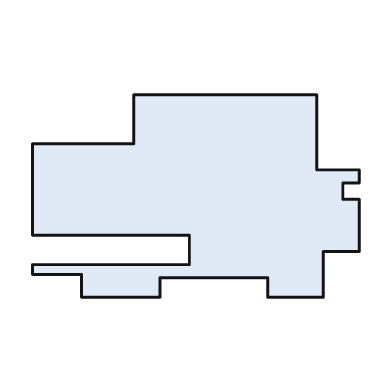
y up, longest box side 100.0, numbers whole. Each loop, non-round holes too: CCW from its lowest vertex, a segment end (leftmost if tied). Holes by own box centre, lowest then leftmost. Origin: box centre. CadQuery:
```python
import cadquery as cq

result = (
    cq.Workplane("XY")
    .moveTo(-35.0, -31.0)
    .lineTo(-11.0, -31.0)
    .lineTo(-11.0, -25.0)
    .lineTo(22.0, -25.0)
    .lineTo(22.0, -31.0)
    .lineTo(39.0, -31.0)
    .lineTo(39.0, -17.0)
    .lineTo(50.0, -17.0)
    .lineTo(50.0, -1.0)
    .lineTo(45.0, -1.0)
    .lineTo(45.0, 4.0)
    .lineTo(50.0, 4.0)
    .lineTo(50.0, 8.0)
    .lineTo(37.0, 8.0)
    .lineTo(37.0, 31.0)
    .lineTo(-19.0, 31.0)
    .lineTo(-19.0, 16.0)
    .lineTo(-50.0, 16.0)
    .lineTo(-50.0, -12.0)
    .lineTo(-2.0, -12.0)
    .lineTo(-2.0, -21.0)
    .lineTo(-50.0, -21.0)
    .lineTo(-50.0, -24.0)
    .lineTo(-35.0, -24.0)
    .close()
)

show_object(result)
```